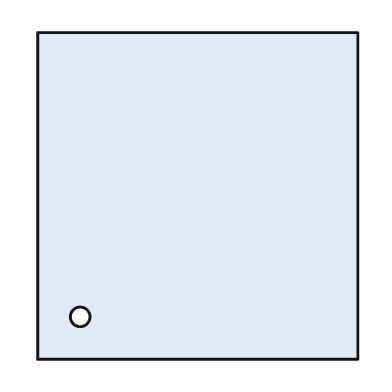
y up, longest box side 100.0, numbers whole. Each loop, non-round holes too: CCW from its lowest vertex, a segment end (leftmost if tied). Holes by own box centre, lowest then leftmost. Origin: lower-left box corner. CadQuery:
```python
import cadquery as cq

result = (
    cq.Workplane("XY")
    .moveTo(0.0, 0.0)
    .lineTo(98.0, 0.0)
    .lineTo(98.0, 100.0)
    .lineTo(0.0, 100.0)
    .close()
    .moveTo(13.0, 13.0)
    .circle(3.0)
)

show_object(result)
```